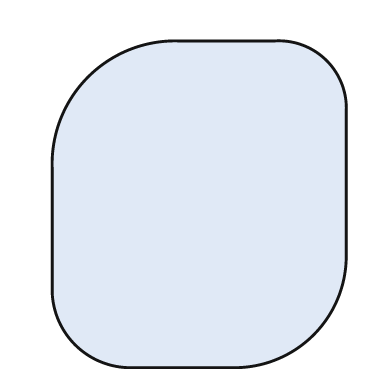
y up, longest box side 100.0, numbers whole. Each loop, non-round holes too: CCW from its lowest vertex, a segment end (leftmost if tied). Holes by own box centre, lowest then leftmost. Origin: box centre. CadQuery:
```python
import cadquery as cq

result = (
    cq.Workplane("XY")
    .moveTo(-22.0, -50.0)
    .lineTo(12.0, -50.0)
    .threePointArc((35.0, -40.0), (45.0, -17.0))
    .lineTo(45.0, 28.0)
    .threePointArc((39.0, 44.0), (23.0, 50.0))
    .lineTo(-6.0, 50.0)
    .threePointArc((-34.0, 39.0), (-45.0, 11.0))
    .lineTo(-45.0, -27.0)
    .threePointArc((-38.0, -43.0), (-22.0, -50.0))
    .close()
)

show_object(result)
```